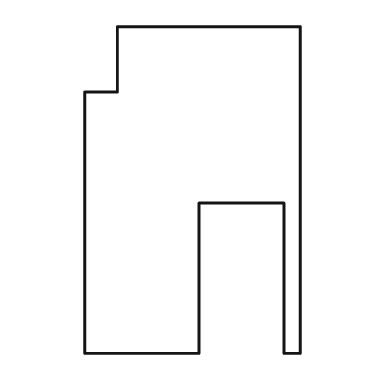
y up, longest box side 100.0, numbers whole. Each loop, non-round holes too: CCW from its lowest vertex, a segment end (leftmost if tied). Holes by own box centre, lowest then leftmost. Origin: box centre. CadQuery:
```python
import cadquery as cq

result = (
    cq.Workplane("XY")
    .moveTo(-33.0, -50.0)
    .lineTo(2.0, -50.0)
    .lineTo(2.0, -4.0)
    .lineTo(28.0, -4.0)
    .lineTo(28.0, -50.0)
    .lineTo(33.0, -50.0)
    .lineTo(33.0, 50.0)
    .lineTo(-23.0, 50.0)
    .lineTo(-23.0, 30.0)
    .lineTo(-33.0, 30.0)
    .close()
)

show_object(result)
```